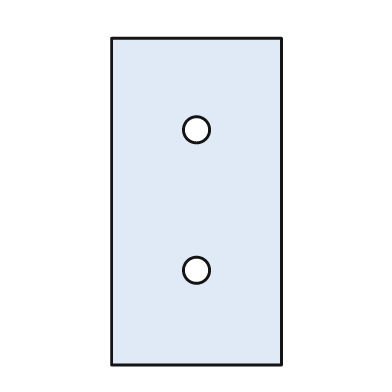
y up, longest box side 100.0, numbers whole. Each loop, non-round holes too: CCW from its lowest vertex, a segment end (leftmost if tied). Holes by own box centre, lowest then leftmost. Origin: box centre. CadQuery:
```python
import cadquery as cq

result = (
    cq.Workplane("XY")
    .moveTo(-26.0, -50.0)
    .lineTo(26.0, -50.0)
    .lineTo(26.0, 50.0)
    .lineTo(-26.0, 50.0)
    .close()
    .moveTo(0.0, -21.0)
    .circle(4.0)
    .moveTo(0.0, 22.0)
    .circle(4.0)
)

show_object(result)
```